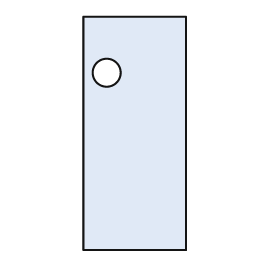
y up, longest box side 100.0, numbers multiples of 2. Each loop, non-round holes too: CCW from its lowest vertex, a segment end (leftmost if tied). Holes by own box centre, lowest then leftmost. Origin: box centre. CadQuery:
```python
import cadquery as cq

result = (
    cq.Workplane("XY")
    .moveTo(-22.0, -50.0)
    .lineTo(22.0, -50.0)
    .lineTo(22.0, 50.0)
    .lineTo(-22.0, 50.0)
    .close()
    .moveTo(-12.0, 26.0)
    .circle(6.0)
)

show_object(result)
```